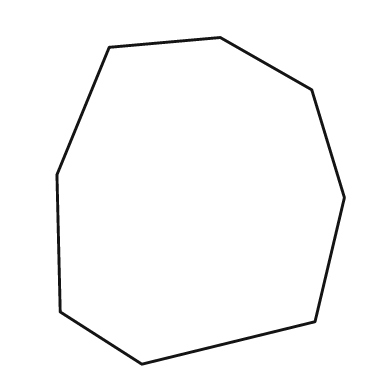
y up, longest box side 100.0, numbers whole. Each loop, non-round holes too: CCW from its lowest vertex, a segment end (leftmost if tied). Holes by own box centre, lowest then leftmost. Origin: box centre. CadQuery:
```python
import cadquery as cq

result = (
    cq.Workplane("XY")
    .moveTo(-18.0, -50.0)
    .lineTo(35.0, -37.0)
    .lineTo(44.0, 1.0)
    .lineTo(34.0, 34.0)
    .lineTo(6.0, 50.0)
    .lineTo(-28.0, 47.0)
    .lineTo(-44.0, 8.0)
    .lineTo(-43.0, -34.0)
    .close()
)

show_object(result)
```